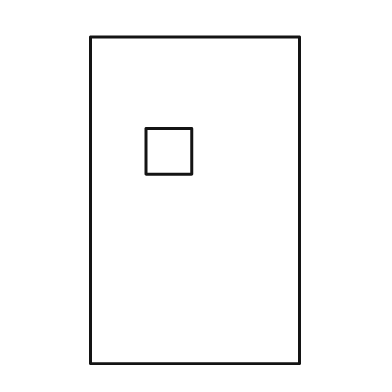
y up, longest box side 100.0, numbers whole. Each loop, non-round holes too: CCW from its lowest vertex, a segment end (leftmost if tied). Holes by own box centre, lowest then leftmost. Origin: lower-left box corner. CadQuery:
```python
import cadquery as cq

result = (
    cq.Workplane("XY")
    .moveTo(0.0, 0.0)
    .lineTo(64.0, 0.0)
    .lineTo(64.0, 100.0)
    .lineTo(0.0, 100.0)
    .close()
    .moveTo(17.0, 58.0)
    .lineTo(31.0, 58.0)
    .lineTo(31.0, 72.0)
    .lineTo(17.0, 72.0)
    .close()
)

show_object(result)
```